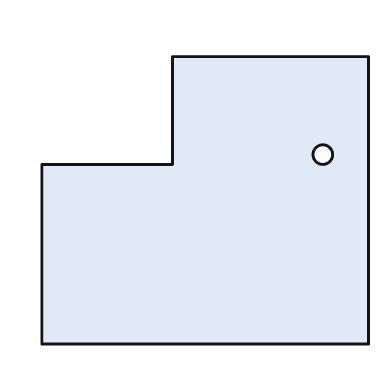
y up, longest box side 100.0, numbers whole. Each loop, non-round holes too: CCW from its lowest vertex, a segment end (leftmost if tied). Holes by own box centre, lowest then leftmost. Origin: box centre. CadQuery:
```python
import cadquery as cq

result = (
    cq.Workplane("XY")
    .moveTo(-50.0, -44.0)
    .lineTo(50.0, -44.0)
    .lineTo(50.0, 44.0)
    .lineTo(-10.0, 44.0)
    .lineTo(-10.0, 11.0)
    .lineTo(-50.0, 11.0)
    .close()
    .moveTo(36.0, 14.0)
    .circle(3.0)
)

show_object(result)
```